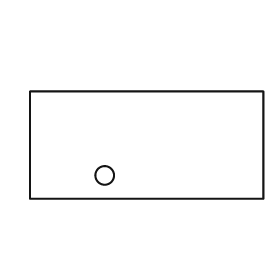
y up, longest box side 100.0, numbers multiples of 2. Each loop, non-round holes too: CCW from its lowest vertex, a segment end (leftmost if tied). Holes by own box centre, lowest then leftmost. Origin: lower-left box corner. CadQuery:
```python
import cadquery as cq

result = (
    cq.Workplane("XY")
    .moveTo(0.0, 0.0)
    .lineTo(100.0, 0.0)
    .lineTo(100.0, 46.0)
    .lineTo(0.0, 46.0)
    .close()
    .moveTo(32.0, 10.0)
    .circle(4.0)
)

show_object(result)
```